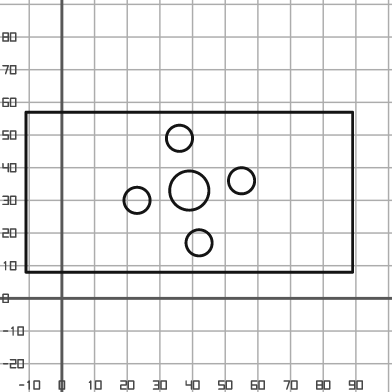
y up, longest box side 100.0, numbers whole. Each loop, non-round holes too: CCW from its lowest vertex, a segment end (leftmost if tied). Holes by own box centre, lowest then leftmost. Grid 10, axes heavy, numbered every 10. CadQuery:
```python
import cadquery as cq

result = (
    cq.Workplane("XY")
    .moveTo(-11.0, 8.0)
    .lineTo(89.0, 8.0)
    .lineTo(89.0, 57.0)
    .lineTo(-11.0, 57.0)
    .close()
    .moveTo(42.0, 17.0)
    .circle(4.0)
    .moveTo(23.0, 30.0)
    .circle(4.0)
    .moveTo(39.0, 33.0)
    .circle(6.0)
    .moveTo(55.0, 36.0)
    .circle(4.0)
    .moveTo(36.0, 49.0)
    .circle(4.0)
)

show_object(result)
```